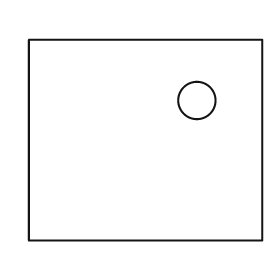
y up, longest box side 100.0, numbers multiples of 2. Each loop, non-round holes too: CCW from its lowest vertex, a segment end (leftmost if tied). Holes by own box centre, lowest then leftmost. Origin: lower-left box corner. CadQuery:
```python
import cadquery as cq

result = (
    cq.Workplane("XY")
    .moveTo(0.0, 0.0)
    .lineTo(100.0, 0.0)
    .lineTo(100.0, 86.0)
    .lineTo(0.0, 86.0)
    .close()
    .moveTo(72.0, 60.0)
    .circle(8.0)
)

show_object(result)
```